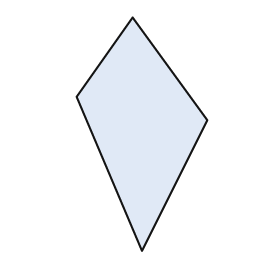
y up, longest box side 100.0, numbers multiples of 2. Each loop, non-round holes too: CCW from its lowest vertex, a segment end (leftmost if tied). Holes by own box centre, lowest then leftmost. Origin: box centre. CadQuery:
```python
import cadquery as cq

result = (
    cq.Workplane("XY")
    .moveTo(0.0, -50.0)
    .lineTo(28.0, 6.0)
    .lineTo(-4.0, 50.0)
    .lineTo(-28.0, 16.0)
    .close()
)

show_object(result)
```